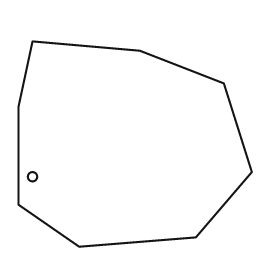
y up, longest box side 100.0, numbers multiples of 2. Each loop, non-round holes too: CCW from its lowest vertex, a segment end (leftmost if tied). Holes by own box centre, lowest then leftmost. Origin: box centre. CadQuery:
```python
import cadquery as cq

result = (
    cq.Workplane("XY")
    .moveTo(-24.0, -44.0)
    .lineTo(26.0, -40.0)
    .lineTo(50.0, -12.0)
    .lineTo(38.0, 26.0)
    .lineTo(2.0, 40.0)
    .lineTo(-44.0, 44.0)
    .lineTo(-50.0, 16.0)
    .lineTo(-50.0, -26.0)
    .close()
    .moveTo(-44.0, -14.0)
    .circle(2.0)
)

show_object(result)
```